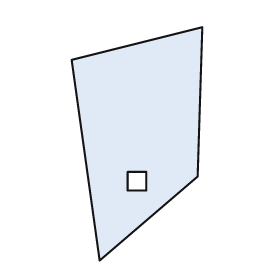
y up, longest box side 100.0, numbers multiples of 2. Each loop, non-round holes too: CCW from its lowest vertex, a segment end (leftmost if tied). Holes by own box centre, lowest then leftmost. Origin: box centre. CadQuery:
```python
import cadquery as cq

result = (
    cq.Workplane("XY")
    .moveTo(-16.0, -50.0)
    .lineTo(26.0, -14.0)
    .lineTo(28.0, 50.0)
    .lineTo(-28.0, 36.0)
    .close()
    .moveTo(-4.0, -20.0)
    .lineTo(4.0, -20.0)
    .lineTo(4.0, -12.0)
    .lineTo(-4.0, -12.0)
    .close()
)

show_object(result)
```